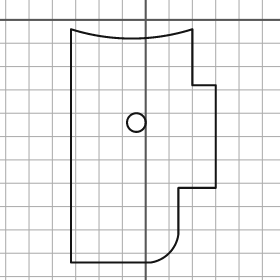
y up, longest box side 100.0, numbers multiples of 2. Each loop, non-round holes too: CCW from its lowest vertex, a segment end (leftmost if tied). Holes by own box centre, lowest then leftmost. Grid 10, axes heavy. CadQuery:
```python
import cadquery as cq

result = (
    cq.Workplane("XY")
    .moveTo(-32.0, -104.0)
    .lineTo(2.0, -104.0)
    .threePointArc((10.0, -100.0), (14.0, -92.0))
    .lineTo(14.0, -72.0)
    .lineTo(30.0, -72.0)
    .lineTo(30.0, -28.0)
    .lineTo(20.0, -28.0)
    .lineTo(20.0, -4.0)
    .threePointArc((-6.0, -8.0), (-32.0, -4.0))
    .close()
    .moveTo(-4.0, -44.0)
    .circle(4.0)
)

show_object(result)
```